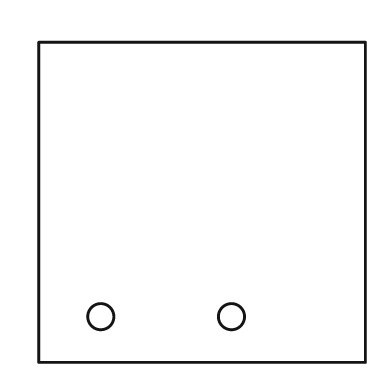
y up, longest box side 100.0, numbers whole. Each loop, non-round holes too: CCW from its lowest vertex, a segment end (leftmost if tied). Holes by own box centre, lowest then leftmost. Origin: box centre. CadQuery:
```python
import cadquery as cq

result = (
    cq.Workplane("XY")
    .moveTo(-50.0, -49.0)
    .lineTo(50.0, -49.0)
    .lineTo(50.0, 49.0)
    .lineTo(-50.0, 49.0)
    .close()
    .moveTo(-31.0, -35.0)
    .circle(4.0)
    .moveTo(9.0, -35.0)
    .circle(4.0)
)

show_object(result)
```